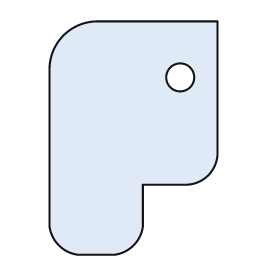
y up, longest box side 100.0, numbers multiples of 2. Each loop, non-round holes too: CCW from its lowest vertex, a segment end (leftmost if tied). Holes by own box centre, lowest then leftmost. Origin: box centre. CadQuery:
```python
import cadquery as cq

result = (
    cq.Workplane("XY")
    .moveTo(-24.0, -50.0)
    .lineTo(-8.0, -50.0)
    .threePointArc((0.0, -46.0), (4.0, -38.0))
    .lineTo(4.0, -20.0)
    .lineTo(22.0, -20.0)
    .threePointArc((32.0, -16.0), (36.0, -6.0))
    .lineTo(36.0, 50.0)
    .lineTo(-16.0, 50.0)
    .threePointArc((-30.0, 44.0), (-36.0, 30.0))
    .lineTo(-36.0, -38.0)
    .threePointArc((-32.0, -46.0), (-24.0, -50.0))
    .close()
    .moveTo(20.0, 26.0)
    .circle(6.0)
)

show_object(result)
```